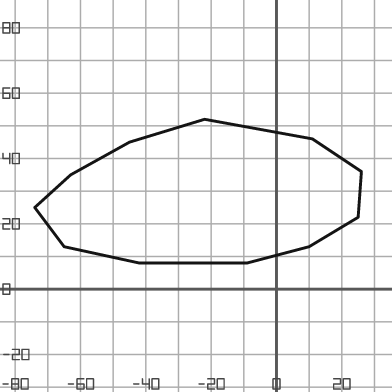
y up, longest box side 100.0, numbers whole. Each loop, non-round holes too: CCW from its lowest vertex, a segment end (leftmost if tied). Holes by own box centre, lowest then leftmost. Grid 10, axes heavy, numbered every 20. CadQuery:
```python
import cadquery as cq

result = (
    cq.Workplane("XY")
    .moveTo(-42.0, 8.0)
    .lineTo(-9.0, 8.0)
    .lineTo(10.0, 13.0)
    .lineTo(25.0, 22.0)
    .lineTo(26.0, 36.0)
    .lineTo(11.0, 46.0)
    .lineTo(-22.0, 52.0)
    .lineTo(-45.0, 45.0)
    .lineTo(-63.0, 35.0)
    .lineTo(-74.0, 25.0)
    .lineTo(-65.0, 13.0)
    .close()
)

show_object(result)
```